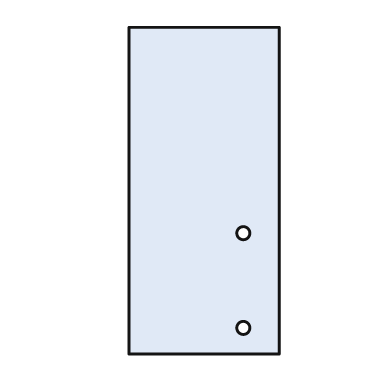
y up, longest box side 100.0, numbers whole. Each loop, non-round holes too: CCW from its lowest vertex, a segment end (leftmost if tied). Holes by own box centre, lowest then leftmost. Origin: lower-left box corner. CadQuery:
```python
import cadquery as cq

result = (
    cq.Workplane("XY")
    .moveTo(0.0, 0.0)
    .lineTo(46.0, 0.0)
    .lineTo(46.0, 100.0)
    .lineTo(0.0, 100.0)
    .close()
    .moveTo(35.0, 8.0)
    .circle(2.0)
    .moveTo(35.0, 37.0)
    .circle(2.0)
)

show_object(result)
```